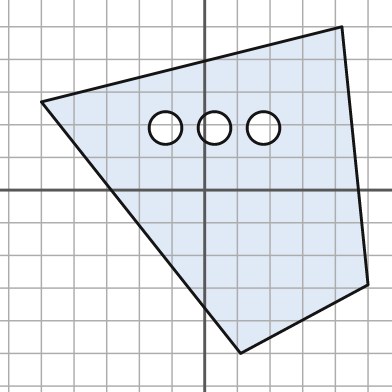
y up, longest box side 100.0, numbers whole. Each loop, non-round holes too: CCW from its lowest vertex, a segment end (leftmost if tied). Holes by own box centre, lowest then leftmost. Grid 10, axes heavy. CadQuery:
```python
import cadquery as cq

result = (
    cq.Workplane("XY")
    .moveTo(11.0, -50.0)
    .lineTo(50.0, -29.0)
    .lineTo(42.0, 50.0)
    .lineTo(-50.0, 27.0)
    .close()
    .moveTo(-12.0, 19.0)
    .circle(5.0)
    .moveTo(3.0, 19.0)
    .circle(5.0)
    .moveTo(18.0, 19.0)
    .circle(5.0)
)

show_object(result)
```